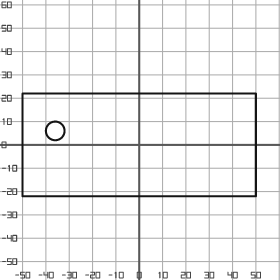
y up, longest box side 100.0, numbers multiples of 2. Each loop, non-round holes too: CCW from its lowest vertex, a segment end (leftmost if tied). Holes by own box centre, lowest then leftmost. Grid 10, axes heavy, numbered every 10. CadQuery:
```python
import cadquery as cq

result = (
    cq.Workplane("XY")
    .moveTo(-50.0, -22.0)
    .lineTo(50.0, -22.0)
    .lineTo(50.0, 22.0)
    .lineTo(-50.0, 22.0)
    .close()
    .moveTo(-36.0, 6.0)
    .circle(4.0)
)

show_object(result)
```